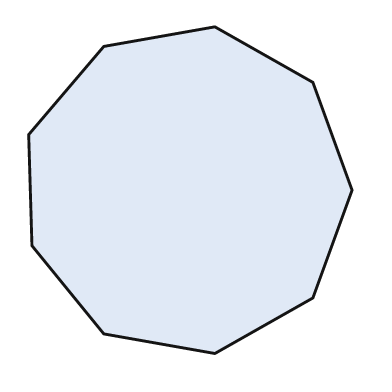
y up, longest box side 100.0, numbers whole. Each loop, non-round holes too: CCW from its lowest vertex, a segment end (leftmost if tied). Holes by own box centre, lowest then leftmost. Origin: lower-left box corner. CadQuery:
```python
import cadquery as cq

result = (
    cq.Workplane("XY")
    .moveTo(57.0, 0.0)
    .lineTo(87.0, 17.0)
    .lineTo(99.0, 50.0)
    .lineTo(87.0, 83.0)
    .lineTo(57.0, 100.0)
    .lineTo(23.0, 94.0)
    .lineTo(0.0, 67.0)
    .lineTo(1.0, 33.0)
    .lineTo(23.0, 6.0)
    .close()
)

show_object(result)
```